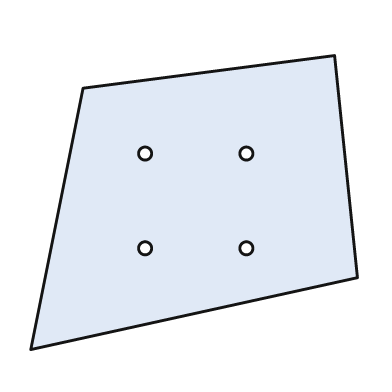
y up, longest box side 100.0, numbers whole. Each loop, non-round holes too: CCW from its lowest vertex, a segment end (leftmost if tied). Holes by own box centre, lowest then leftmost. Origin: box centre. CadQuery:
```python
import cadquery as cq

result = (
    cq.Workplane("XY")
    .moveTo(-50.0, -45.0)
    .lineTo(50.0, -23.0)
    .lineTo(43.0, 45.0)
    .lineTo(-34.0, 35.0)
    .close()
    .moveTo(-15.0, -14.0)
    .circle(2.0)
    .moveTo(16.0, -14.0)
    .circle(2.0)
    .moveTo(-15.0, 15.0)
    .circle(2.0)
    .moveTo(16.0, 15.0)
    .circle(2.0)
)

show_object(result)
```